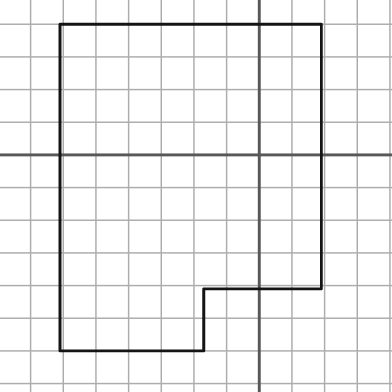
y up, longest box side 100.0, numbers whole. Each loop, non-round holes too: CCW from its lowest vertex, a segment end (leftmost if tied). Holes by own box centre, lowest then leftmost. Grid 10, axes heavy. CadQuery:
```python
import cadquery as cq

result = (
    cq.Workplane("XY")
    .moveTo(-61.0, -60.0)
    .lineTo(-17.0, -60.0)
    .lineTo(-17.0, -41.0)
    .lineTo(19.0, -41.0)
    .lineTo(19.0, 40.0)
    .lineTo(-61.0, 40.0)
    .close()
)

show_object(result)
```